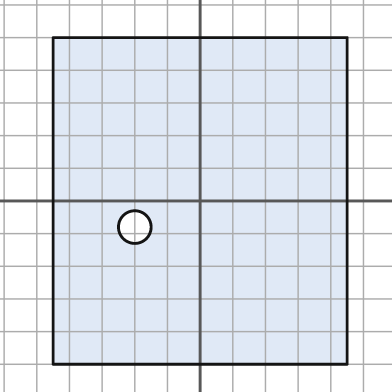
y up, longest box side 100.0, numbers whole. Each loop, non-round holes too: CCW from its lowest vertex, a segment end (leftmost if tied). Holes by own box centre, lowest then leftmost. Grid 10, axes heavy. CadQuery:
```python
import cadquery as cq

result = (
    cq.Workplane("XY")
    .moveTo(-45.0, -50.0)
    .lineTo(45.0, -50.0)
    .lineTo(45.0, 50.0)
    .lineTo(-45.0, 50.0)
    .close()
    .moveTo(-20.0, -8.0)
    .circle(5.0)
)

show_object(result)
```